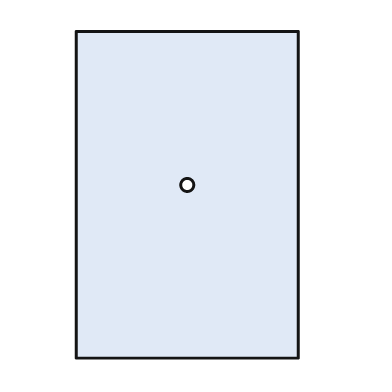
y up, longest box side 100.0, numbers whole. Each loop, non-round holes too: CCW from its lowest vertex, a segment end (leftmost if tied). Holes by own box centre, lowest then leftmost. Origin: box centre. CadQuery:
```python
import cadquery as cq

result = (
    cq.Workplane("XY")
    .moveTo(-34.0, -50.0)
    .lineTo(34.0, -50.0)
    .lineTo(34.0, 50.0)
    .lineTo(-34.0, 50.0)
    .close()
    .moveTo(0.0, 3.0)
    .circle(2.0)
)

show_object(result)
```